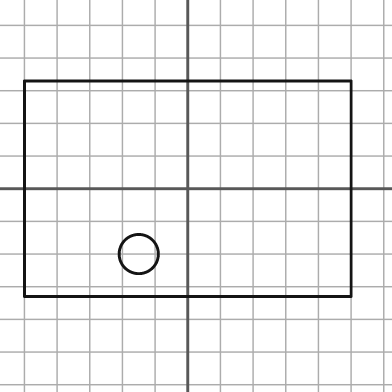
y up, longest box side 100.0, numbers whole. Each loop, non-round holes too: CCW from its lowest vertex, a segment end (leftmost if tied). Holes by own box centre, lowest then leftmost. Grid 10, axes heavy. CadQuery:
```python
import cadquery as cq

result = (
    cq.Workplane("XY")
    .moveTo(-50.0, -33.0)
    .lineTo(50.0, -33.0)
    .lineTo(50.0, 33.0)
    .lineTo(-50.0, 33.0)
    .close()
    .moveTo(-15.0, -20.0)
    .circle(6.0)
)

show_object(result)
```